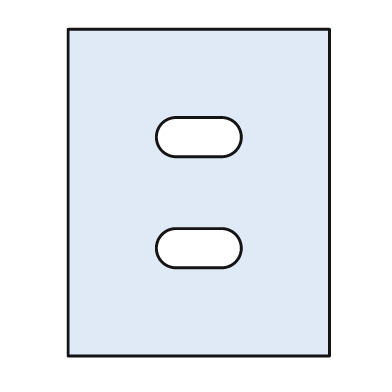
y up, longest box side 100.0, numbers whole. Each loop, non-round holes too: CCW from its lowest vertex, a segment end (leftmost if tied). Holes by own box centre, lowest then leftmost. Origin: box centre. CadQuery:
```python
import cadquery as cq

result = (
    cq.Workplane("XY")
    .moveTo(-40.0, -50.0)
    .lineTo(40.0, -50.0)
    .lineTo(40.0, 50.0)
    .lineTo(-40.0, 50.0)
    .close()
    .moveTo(-7.0, -23.0)
    .lineTo(7.0, -23.0)
    .threePointArc((13.0, -17.0), (7.0, -11.0))
    .lineTo(-7.0, -11.0)
    .threePointArc((-13.0, -17.0), (-7.0, -23.0))
    .close()
    .moveTo(-7.0, 11.0)
    .lineTo(7.0, 11.0)
    .threePointArc((13.0, 17.0), (7.0, 23.0))
    .lineTo(-7.0, 23.0)
    .threePointArc((-13.0, 17.0), (-7.0, 11.0))
    .close()
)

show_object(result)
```